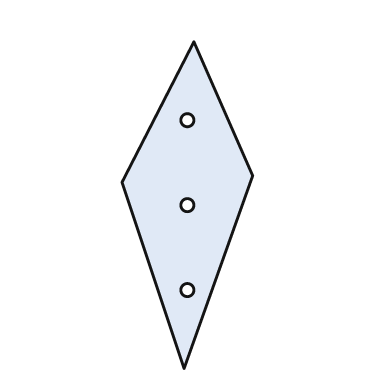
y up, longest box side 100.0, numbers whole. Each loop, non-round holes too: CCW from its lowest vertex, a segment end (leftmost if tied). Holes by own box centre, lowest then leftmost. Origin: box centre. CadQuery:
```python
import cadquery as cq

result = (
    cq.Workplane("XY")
    .moveTo(-1.0, -50.0)
    .lineTo(20.0, 9.0)
    .lineTo(2.0, 50.0)
    .lineTo(-20.0, 7.0)
    .close()
    .moveTo(0.0, -26.0)
    .circle(2.0)
    .moveTo(0.0, 0.0)
    .circle(2.0)
    .moveTo(0.0, 26.0)
    .circle(2.0)
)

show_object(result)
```